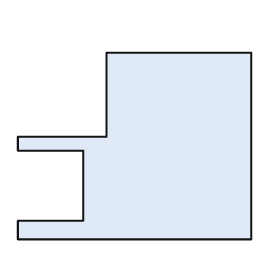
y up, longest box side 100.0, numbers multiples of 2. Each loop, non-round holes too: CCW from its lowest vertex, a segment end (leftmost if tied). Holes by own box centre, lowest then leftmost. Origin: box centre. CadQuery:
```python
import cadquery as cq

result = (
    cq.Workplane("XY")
    .moveTo(-50.0, -40.0)
    .lineTo(50.0, -40.0)
    .lineTo(50.0, 40.0)
    .lineTo(-12.0, 40.0)
    .lineTo(-12.0, 4.0)
    .lineTo(-50.0, 4.0)
    .lineTo(-50.0, -2.0)
    .lineTo(-22.0, -2.0)
    .lineTo(-22.0, -32.0)
    .lineTo(-50.0, -32.0)
    .close()
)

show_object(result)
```